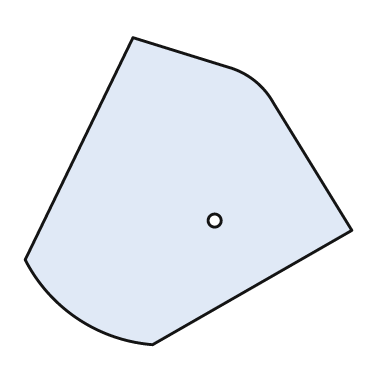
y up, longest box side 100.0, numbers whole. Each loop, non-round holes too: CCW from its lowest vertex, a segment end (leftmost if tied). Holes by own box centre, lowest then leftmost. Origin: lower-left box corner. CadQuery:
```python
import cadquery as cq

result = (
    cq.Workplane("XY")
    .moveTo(39.0, 0.0)
    .lineTo(100.0, 35.0)
    .lineTo(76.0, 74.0)
    .threePointArc((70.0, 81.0), (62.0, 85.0))
    .lineTo(33.0, 94.0)
    .lineTo(0.0, 26.0)
    .threePointArc((16.0, 8.0), (39.0, 0.0))
    .close()
    .moveTo(58.0, 38.0)
    .circle(2.0)
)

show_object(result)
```